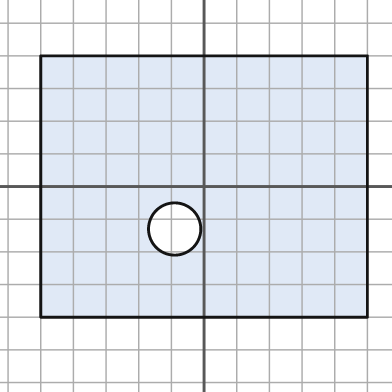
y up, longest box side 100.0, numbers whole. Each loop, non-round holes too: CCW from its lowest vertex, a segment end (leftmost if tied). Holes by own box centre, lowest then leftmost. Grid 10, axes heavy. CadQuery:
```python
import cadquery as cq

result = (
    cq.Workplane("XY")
    .moveTo(-50.0, -40.0)
    .lineTo(50.0, -40.0)
    .lineTo(50.0, 40.0)
    .lineTo(-50.0, 40.0)
    .close()
    .moveTo(-9.0, -13.0)
    .circle(8.0)
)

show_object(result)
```